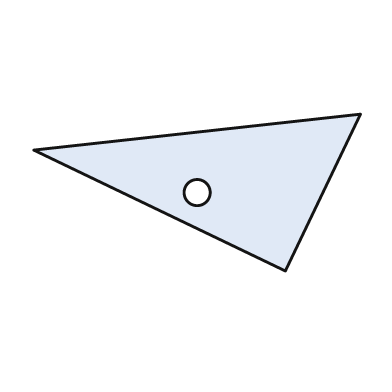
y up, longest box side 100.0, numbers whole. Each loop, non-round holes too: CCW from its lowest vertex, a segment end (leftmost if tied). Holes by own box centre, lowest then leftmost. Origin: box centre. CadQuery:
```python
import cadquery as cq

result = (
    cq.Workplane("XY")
    .moveTo(27.0, -24.0)
    .lineTo(50.0, 24.0)
    .lineTo(-50.0, 13.0)
    .close()
    .moveTo(0.0, 0.0)
    .circle(4.0)
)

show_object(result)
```